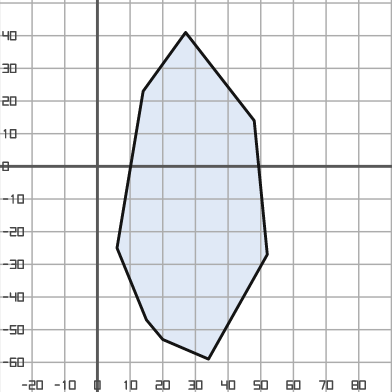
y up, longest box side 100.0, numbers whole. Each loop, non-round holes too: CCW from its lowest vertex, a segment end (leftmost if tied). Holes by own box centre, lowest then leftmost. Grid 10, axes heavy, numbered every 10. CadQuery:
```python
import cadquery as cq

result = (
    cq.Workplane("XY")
    .moveTo(34.0, -59.0)
    .lineTo(52.0, -27.0)
    .lineTo(48.0, 14.0)
    .lineTo(27.0, 41.0)
    .lineTo(14.0, 23.0)
    .lineTo(6.0, -25.0)
    .lineTo(15.0, -47.0)
    .lineTo(20.0, -53.0)
    .close()
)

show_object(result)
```